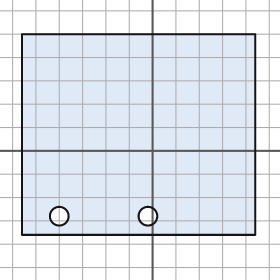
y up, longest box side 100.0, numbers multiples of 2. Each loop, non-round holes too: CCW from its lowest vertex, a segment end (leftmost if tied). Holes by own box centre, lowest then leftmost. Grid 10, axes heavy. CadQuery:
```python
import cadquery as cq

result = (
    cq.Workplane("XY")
    .moveTo(-56.0, -36.0)
    .lineTo(44.0, -36.0)
    .lineTo(44.0, 50.0)
    .lineTo(-56.0, 50.0)
    .close()
    .moveTo(-40.0, -28.0)
    .circle(4.0)
    .moveTo(-2.0, -28.0)
    .circle(4.0)
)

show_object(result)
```